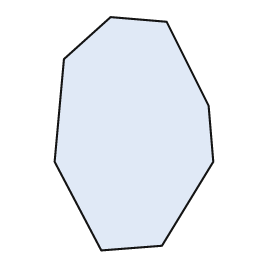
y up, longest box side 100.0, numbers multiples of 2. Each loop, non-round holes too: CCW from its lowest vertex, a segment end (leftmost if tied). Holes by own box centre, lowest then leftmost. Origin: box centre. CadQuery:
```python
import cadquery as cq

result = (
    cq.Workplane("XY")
    .moveTo(-14.0, -50.0)
    .lineTo(12.0, -48.0)
    .lineTo(34.0, -12.0)
    .lineTo(32.0, 12.0)
    .lineTo(14.0, 48.0)
    .lineTo(-10.0, 50.0)
    .lineTo(-30.0, 32.0)
    .lineTo(-34.0, -12.0)
    .close()
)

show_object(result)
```